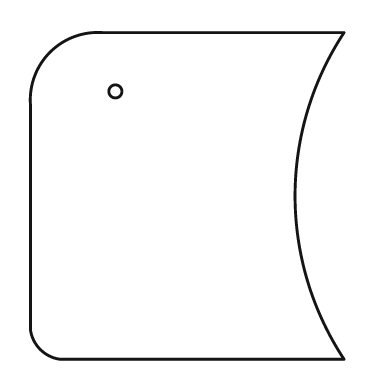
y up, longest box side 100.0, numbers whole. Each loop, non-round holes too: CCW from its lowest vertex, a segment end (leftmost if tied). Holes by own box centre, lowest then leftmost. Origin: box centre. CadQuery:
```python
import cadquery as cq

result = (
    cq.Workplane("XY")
    .moveTo(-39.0, -50.0)
    .lineTo(48.0, -50.0)
    .threePointArc((33.0, 0.0), (48.0, 50.0))
    .lineTo(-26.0, 50.0)
    .threePointArc((-42.0, 44.0), (-48.0, 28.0))
    .lineTo(-48.0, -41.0)
    .threePointArc((-45.0, -47.0), (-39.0, -50.0))
    .close()
    .moveTo(-22.0, 32.0)
    .circle(2.0)
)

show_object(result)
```